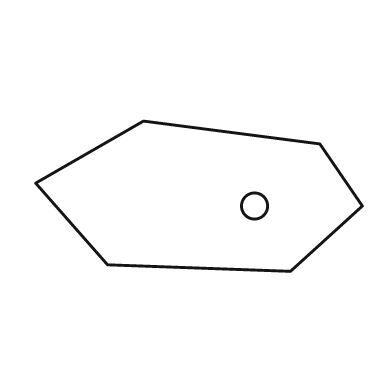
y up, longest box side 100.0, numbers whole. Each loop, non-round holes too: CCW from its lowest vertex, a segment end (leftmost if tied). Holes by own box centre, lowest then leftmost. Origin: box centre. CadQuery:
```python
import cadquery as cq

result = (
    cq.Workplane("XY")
    .moveTo(28.0, -23.0)
    .lineTo(50.0, -3.0)
    .lineTo(37.0, 16.0)
    .lineTo(-17.0, 23.0)
    .lineTo(-50.0, 4.0)
    .lineTo(-28.0, -21.0)
    .close()
    .moveTo(17.0, -3.0)
    .circle(4.0)
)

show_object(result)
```